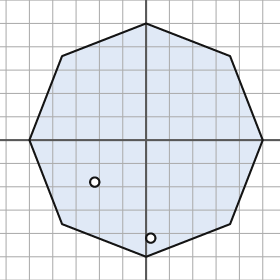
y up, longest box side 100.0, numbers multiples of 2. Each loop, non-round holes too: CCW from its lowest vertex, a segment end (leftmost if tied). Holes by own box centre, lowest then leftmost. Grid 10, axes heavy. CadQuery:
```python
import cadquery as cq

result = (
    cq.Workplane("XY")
    .moveTo(0.0, -50.0)
    .lineTo(36.0, -36.0)
    .lineTo(50.0, 0.0)
    .lineTo(36.0, 36.0)
    .lineTo(0.0, 50.0)
    .lineTo(-36.0, 36.0)
    .lineTo(-50.0, 0.0)
    .lineTo(-36.0, -36.0)
    .close()
    .moveTo(2.0, -42.0)
    .circle(2.0)
    .moveTo(-22.0, -18.0)
    .circle(2.0)
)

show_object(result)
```